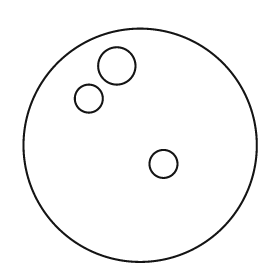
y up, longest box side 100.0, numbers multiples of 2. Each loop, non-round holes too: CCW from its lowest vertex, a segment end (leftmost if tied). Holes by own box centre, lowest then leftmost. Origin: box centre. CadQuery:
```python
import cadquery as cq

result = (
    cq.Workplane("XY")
    .moveTo(0.0, 0.0)
    .circle(50.0)
    .moveTo(10.0, -8.0)
    .circle(6.0)
    .moveTo(-22.0, 20.0)
    .circle(6.0)
    .moveTo(-10.0, 34.0)
    .circle(8.0)
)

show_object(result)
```